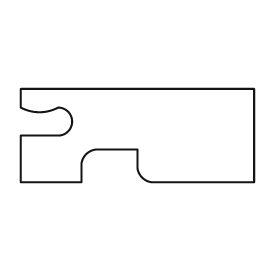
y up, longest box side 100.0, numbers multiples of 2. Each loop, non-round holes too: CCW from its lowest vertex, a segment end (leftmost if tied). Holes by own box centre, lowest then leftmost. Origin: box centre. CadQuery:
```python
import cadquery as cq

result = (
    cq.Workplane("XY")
    .moveTo(-50.0, -20.0)
    .lineTo(-24.0, -20.0)
    .lineTo(-24.0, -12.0)
    .threePointArc((-22.0, -8.0), (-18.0, -6.0))
    .lineTo(0.0, -6.0)
    .lineTo(0.0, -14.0)
    .threePointArc((2.0, -18.0), (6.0, -20.0))
    .lineTo(50.0, -20.0)
    .lineTo(50.0, 20.0)
    .lineTo(-50.0, 20.0)
    .lineTo(-50.0, 12.0)
    .threePointArc((-42.0, 10.0), (-34.0, 12.0))
    .threePointArc((-28.0, 6.0), (-34.0, 0.0))
    .lineTo(-50.0, 0.0)
    .close()
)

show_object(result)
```